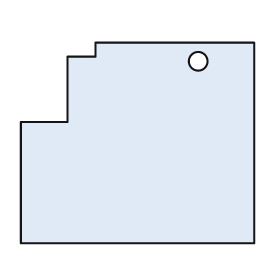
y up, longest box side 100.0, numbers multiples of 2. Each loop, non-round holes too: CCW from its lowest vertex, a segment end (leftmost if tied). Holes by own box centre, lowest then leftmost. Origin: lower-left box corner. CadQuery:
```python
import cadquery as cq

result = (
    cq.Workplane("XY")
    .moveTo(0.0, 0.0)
    .lineTo(100.0, 0.0)
    .lineTo(100.0, 86.0)
    .lineTo(32.0, 86.0)
    .lineTo(32.0, 80.0)
    .lineTo(20.0, 80.0)
    .lineTo(20.0, 52.0)
    .lineTo(0.0, 52.0)
    .close()
    .moveTo(76.0, 78.0)
    .circle(4.0)
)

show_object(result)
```